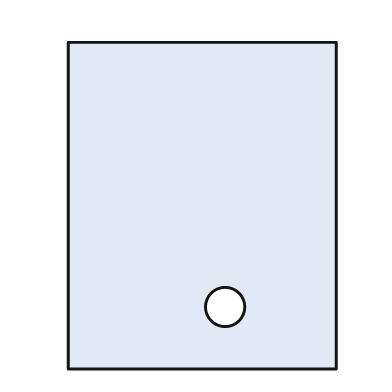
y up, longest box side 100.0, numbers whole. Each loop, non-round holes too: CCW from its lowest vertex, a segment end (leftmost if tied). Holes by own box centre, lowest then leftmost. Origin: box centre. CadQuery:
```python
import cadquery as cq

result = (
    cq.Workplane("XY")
    .moveTo(-41.0, -50.0)
    .lineTo(41.0, -50.0)
    .lineTo(41.0, 50.0)
    .lineTo(-41.0, 50.0)
    .close()
    .moveTo(7.0, -31.0)
    .circle(6.0)
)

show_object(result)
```